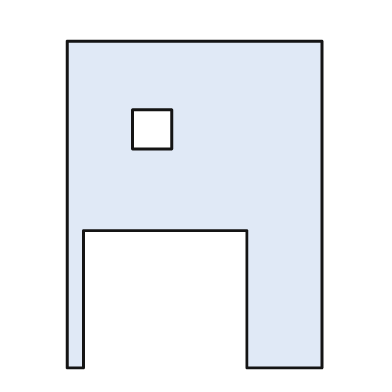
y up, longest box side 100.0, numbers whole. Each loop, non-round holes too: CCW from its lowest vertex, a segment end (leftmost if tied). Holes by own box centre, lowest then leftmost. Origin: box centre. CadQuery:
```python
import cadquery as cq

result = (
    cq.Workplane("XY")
    .moveTo(-39.0, -50.0)
    .lineTo(-34.0, -50.0)
    .lineTo(-34.0, -8.0)
    .lineTo(16.0, -8.0)
    .lineTo(16.0, -50.0)
    .lineTo(39.0, -50.0)
    .lineTo(39.0, 50.0)
    .lineTo(-39.0, 50.0)
    .close()
    .moveTo(-19.0, 17.0)
    .lineTo(-7.0, 17.0)
    .lineTo(-7.0, 29.0)
    .lineTo(-19.0, 29.0)
    .close()
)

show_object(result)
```